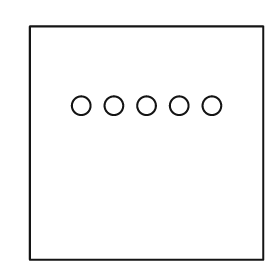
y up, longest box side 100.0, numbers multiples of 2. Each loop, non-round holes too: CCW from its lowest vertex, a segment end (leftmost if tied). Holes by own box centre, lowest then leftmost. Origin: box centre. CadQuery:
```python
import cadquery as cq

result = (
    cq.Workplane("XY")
    .moveTo(-50.0, -50.0)
    .lineTo(50.0, -50.0)
    .lineTo(50.0, 50.0)
    .lineTo(-50.0, 50.0)
    .close()
    .moveTo(-28.0, 16.0)
    .circle(4.0)
    .moveTo(-14.0, 16.0)
    .circle(4.0)
    .moveTo(0.0, 16.0)
    .circle(4.0)
    .moveTo(14.0, 16.0)
    .circle(4.0)
    .moveTo(28.0, 16.0)
    .circle(4.0)
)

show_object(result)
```